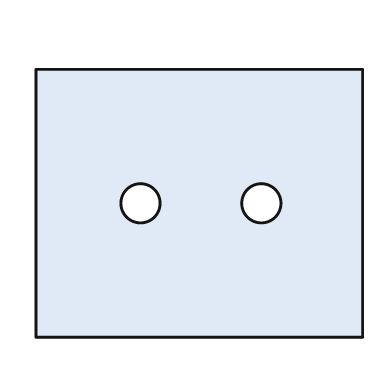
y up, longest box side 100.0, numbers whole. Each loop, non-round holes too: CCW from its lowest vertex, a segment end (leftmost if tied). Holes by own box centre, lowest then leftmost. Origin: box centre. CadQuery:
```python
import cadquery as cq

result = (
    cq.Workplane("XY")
    .moveTo(-50.0, -41.0)
    .lineTo(50.0, -41.0)
    .lineTo(50.0, 41.0)
    .lineTo(-50.0, 41.0)
    .close()
    .moveTo(-18.0, 0.0)
    .circle(6.0)
    .moveTo(19.0, 0.0)
    .circle(6.0)
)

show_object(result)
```